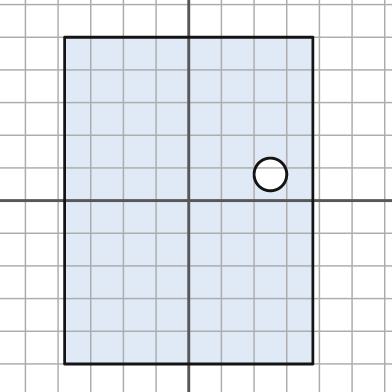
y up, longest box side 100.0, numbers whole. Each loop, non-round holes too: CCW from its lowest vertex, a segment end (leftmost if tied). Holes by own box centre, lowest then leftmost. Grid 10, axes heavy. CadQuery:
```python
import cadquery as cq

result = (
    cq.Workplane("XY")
    .moveTo(-38.0, -50.0)
    .lineTo(38.0, -50.0)
    .lineTo(38.0, 50.0)
    .lineTo(-38.0, 50.0)
    .close()
    .moveTo(25.0, 8.0)
    .circle(5.0)
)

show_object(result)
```